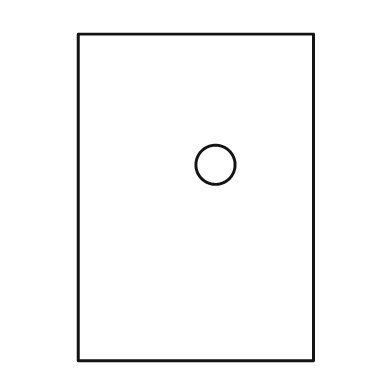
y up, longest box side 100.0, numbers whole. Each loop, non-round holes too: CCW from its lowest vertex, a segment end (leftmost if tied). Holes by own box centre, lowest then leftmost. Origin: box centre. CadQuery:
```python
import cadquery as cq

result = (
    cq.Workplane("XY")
    .moveTo(-36.0, -50.0)
    .lineTo(36.0, -50.0)
    .lineTo(36.0, 50.0)
    .lineTo(-36.0, 50.0)
    .close()
    .moveTo(6.0, 10.0)
    .circle(6.0)
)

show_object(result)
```